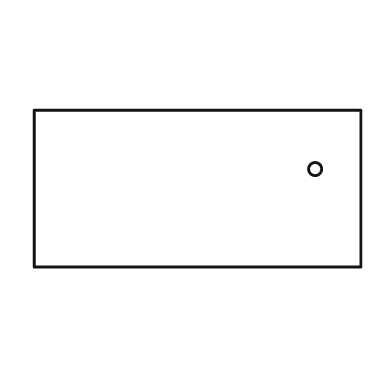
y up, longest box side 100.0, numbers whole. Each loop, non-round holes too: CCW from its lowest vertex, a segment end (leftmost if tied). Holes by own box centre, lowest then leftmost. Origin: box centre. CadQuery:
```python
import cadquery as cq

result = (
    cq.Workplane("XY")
    .moveTo(-50.0, -24.0)
    .lineTo(50.0, -24.0)
    .lineTo(50.0, 24.0)
    .lineTo(-50.0, 24.0)
    .close()
    .moveTo(36.0, 6.0)
    .circle(2.0)
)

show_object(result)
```